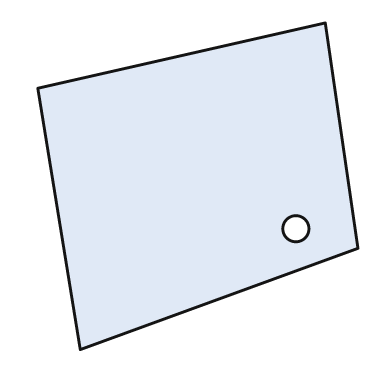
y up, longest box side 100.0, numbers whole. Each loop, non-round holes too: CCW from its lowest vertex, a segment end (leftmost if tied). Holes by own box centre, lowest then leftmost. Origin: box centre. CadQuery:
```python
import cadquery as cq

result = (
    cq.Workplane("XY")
    .moveTo(-36.0, -50.0)
    .lineTo(49.0, -19.0)
    .lineTo(39.0, 50.0)
    .lineTo(-49.0, 30.0)
    .close()
    .moveTo(30.0, -13.0)
    .circle(4.0)
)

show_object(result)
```